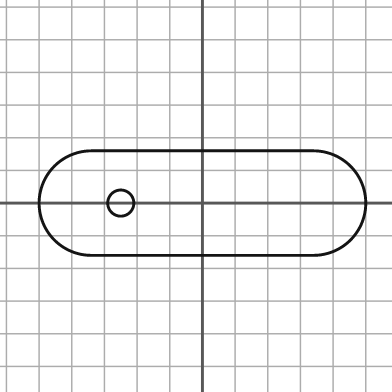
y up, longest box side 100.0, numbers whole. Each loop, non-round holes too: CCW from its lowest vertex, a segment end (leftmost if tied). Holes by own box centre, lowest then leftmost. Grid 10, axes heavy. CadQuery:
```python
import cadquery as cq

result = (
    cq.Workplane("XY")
    .moveTo(-34.0, -16.0)
    .lineTo(34.0, -16.0)
    .threePointArc((50.0, 0.0), (34.0, 16.0))
    .lineTo(-34.0, 16.0)
    .threePointArc((-50.0, 0.0), (-34.0, -16.0))
    .close()
    .moveTo(-25.0, 0.0)
    .circle(4.0)
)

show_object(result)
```